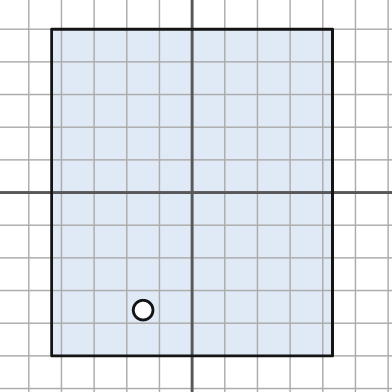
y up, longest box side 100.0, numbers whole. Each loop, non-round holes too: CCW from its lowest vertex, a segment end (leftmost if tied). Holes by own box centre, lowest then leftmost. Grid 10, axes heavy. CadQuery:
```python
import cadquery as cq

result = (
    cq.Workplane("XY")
    .moveTo(-43.0, -50.0)
    .lineTo(43.0, -50.0)
    .lineTo(43.0, 50.0)
    .lineTo(-43.0, 50.0)
    .close()
    .moveTo(-15.0, -36.0)
    .circle(3.0)
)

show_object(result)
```